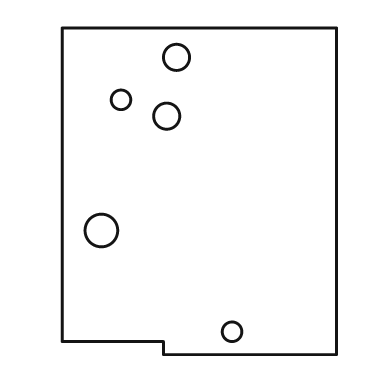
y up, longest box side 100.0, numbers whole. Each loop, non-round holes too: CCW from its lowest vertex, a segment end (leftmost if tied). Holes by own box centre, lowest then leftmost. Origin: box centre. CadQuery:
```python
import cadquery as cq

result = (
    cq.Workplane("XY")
    .moveTo(-11.0, -50.0)
    .lineTo(42.0, -50.0)
    .lineTo(42.0, 50.0)
    .lineTo(-42.0, 50.0)
    .lineTo(-42.0, -46.0)
    .lineTo(-11.0, -46.0)
    .close()
    .moveTo(10.0, -43.0)
    .circle(3.0)
    .moveTo(-30.0, -12.0)
    .circle(5.0)
    .moveTo(-10.0, 23.0)
    .circle(4.0)
    .moveTo(-24.0, 28.0)
    .circle(3.0)
    .moveTo(-7.0, 41.0)
    .circle(4.0)
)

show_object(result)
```